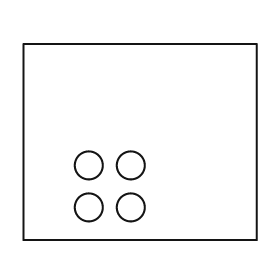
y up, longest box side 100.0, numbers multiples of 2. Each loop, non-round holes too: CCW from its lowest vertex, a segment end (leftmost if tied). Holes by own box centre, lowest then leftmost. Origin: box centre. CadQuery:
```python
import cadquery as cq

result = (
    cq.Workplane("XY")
    .moveTo(-50.0, -42.0)
    .lineTo(50.0, -42.0)
    .lineTo(50.0, 42.0)
    .lineTo(-50.0, 42.0)
    .close()
    .moveTo(-22.0, -28.0)
    .circle(6.0)
    .moveTo(-4.0, -28.0)
    .circle(6.0)
    .moveTo(-22.0, -10.0)
    .circle(6.0)
    .moveTo(-4.0, -10.0)
    .circle(6.0)
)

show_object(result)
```